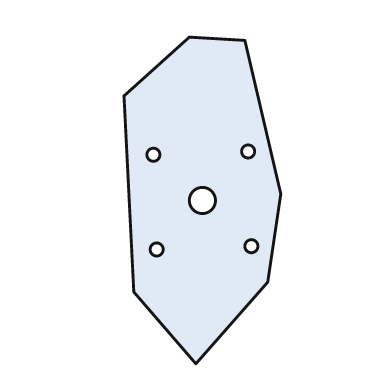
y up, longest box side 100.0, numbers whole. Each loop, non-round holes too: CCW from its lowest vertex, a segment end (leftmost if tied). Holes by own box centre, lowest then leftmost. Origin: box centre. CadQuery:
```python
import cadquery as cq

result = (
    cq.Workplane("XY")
    .moveTo(-2.0, -50.0)
    .lineTo(20.0, -25.0)
    .lineTo(24.0, 2.0)
    .lineTo(13.0, 49.0)
    .lineTo(-4.0, 50.0)
    .lineTo(-24.0, 32.0)
    .lineTo(-21.0, -28.0)
    .close()
    .moveTo(-14.0, -15.0)
    .circle(2.0)
    .moveTo(15.0, -14.0)
    .circle(2.0)
    .moveTo(0.0, 0.0)
    .circle(4.0)
    .moveTo(-15.0, 14.0)
    .circle(2.0)
    .moveTo(14.0, 15.0)
    .circle(2.0)
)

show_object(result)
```